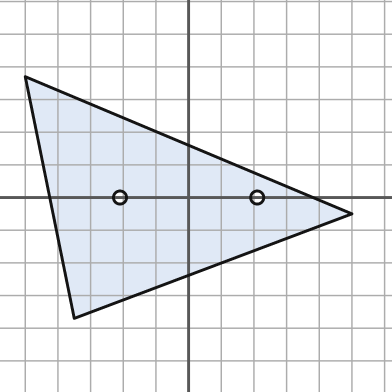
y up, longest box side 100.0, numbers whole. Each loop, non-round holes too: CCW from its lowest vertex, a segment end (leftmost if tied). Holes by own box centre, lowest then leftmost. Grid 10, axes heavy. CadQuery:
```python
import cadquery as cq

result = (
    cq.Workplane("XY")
    .moveTo(-35.0, -37.0)
    .lineTo(50.0, -5.0)
    .lineTo(-50.0, 37.0)
    .close()
    .moveTo(-21.0, 0.0)
    .circle(2.0)
    .moveTo(21.0, 0.0)
    .circle(2.0)
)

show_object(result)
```